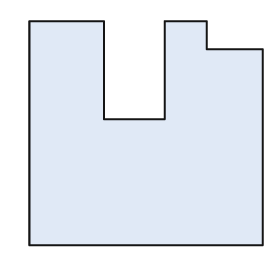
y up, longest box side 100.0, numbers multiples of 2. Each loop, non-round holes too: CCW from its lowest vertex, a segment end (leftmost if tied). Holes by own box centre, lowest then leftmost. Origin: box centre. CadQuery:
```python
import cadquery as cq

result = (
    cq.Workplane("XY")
    .moveTo(-50.0, -48.0)
    .lineTo(50.0, -48.0)
    .lineTo(50.0, 36.0)
    .lineTo(26.0, 36.0)
    .lineTo(26.0, 48.0)
    .lineTo(8.0, 48.0)
    .lineTo(8.0, 6.0)
    .lineTo(-18.0, 6.0)
    .lineTo(-18.0, 48.0)
    .lineTo(-50.0, 48.0)
    .close()
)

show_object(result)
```